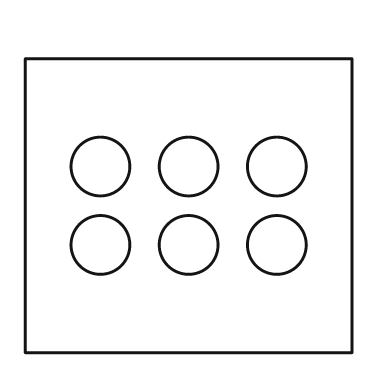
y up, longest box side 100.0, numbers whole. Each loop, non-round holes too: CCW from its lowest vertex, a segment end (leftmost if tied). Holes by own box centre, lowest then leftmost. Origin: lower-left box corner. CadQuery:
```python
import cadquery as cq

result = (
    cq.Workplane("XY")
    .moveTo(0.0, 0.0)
    .lineTo(100.0, 0.0)
    .lineTo(100.0, 90.0)
    .lineTo(0.0, 90.0)
    .close()
    .moveTo(23.0, 33.0)
    .circle(9.0)
    .moveTo(50.0, 33.0)
    .circle(9.0)
    .moveTo(77.0, 33.0)
    .circle(9.0)
    .moveTo(23.0, 57.0)
    .circle(9.0)
    .moveTo(50.0, 57.0)
    .circle(9.0)
    .moveTo(77.0, 57.0)
    .circle(9.0)
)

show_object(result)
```